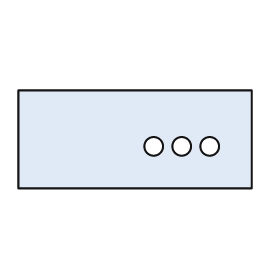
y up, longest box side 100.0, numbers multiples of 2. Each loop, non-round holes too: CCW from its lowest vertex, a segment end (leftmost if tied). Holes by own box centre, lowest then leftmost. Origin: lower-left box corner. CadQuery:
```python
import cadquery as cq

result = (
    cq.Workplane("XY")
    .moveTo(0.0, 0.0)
    .lineTo(100.0, 0.0)
    .lineTo(100.0, 42.0)
    .lineTo(0.0, 42.0)
    .close()
    .moveTo(58.0, 18.0)
    .circle(4.0)
    .moveTo(70.0, 18.0)
    .circle(4.0)
    .moveTo(82.0, 18.0)
    .circle(4.0)
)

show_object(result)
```